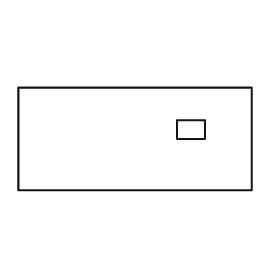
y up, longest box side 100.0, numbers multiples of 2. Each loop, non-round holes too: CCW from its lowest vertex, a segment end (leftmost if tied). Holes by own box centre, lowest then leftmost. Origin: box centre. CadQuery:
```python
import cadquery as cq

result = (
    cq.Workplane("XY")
    .moveTo(-50.0, -22.0)
    .lineTo(50.0, -22.0)
    .lineTo(50.0, 22.0)
    .lineTo(-50.0, 22.0)
    .close()
    .moveTo(18.0, 0.0)
    .lineTo(30.0, 0.0)
    .lineTo(30.0, 8.0)
    .lineTo(18.0, 8.0)
    .close()
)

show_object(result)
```